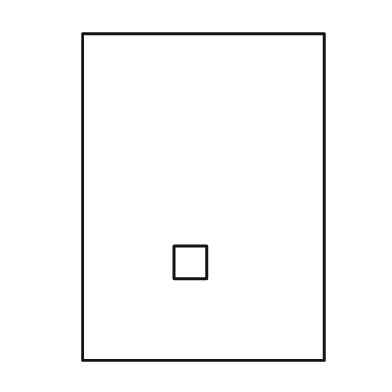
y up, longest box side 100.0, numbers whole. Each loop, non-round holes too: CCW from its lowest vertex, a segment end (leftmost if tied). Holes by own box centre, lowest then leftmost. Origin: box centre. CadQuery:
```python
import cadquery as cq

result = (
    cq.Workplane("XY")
    .moveTo(-37.0, -50.0)
    .lineTo(37.0, -50.0)
    .lineTo(37.0, 50.0)
    .lineTo(-37.0, 50.0)
    .close()
    .moveTo(-9.0, -25.0)
    .lineTo(1.0, -25.0)
    .lineTo(1.0, -15.0)
    .lineTo(-9.0, -15.0)
    .close()
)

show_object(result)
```